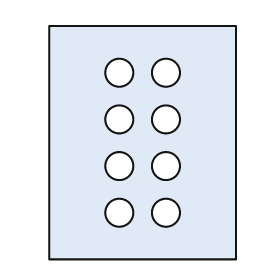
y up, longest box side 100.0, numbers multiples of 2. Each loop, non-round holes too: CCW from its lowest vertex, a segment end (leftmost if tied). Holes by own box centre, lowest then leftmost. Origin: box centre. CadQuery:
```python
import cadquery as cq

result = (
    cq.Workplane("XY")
    .moveTo(-40.0, -50.0)
    .lineTo(40.0, -50.0)
    .lineTo(40.0, 50.0)
    .lineTo(-40.0, 50.0)
    .close()
    .moveTo(-10.0, -30.0)
    .circle(6.0)
    .moveTo(10.0, -30.0)
    .circle(6.0)
    .moveTo(-10.0, -10.0)
    .circle(6.0)
    .moveTo(10.0, -10.0)
    .circle(6.0)
    .moveTo(-10.0, 10.0)
    .circle(6.0)
    .moveTo(10.0, 10.0)
    .circle(6.0)
    .moveTo(-10.0, 30.0)
    .circle(6.0)
    .moveTo(10.0, 30.0)
    .circle(6.0)
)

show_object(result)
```